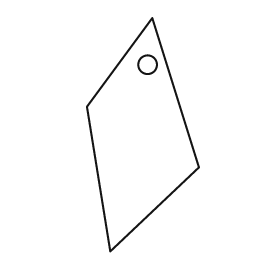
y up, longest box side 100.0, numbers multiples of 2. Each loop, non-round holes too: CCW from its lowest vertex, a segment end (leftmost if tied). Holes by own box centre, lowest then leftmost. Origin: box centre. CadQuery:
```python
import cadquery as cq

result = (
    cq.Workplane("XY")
    .moveTo(-14.0, -50.0)
    .lineTo(24.0, -14.0)
    .lineTo(4.0, 50.0)
    .lineTo(-24.0, 12.0)
    .close()
    .moveTo(2.0, 30.0)
    .circle(4.0)
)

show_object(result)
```